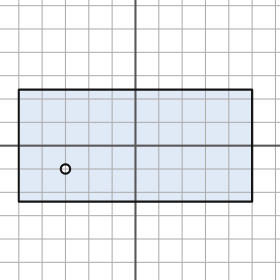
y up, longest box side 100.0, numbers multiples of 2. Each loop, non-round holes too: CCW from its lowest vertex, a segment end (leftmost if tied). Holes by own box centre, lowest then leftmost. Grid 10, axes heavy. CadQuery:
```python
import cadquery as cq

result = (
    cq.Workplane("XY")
    .moveTo(-50.0, -24.0)
    .lineTo(50.0, -24.0)
    .lineTo(50.0, 24.0)
    .lineTo(-50.0, 24.0)
    .close()
    .moveTo(-30.0, -10.0)
    .circle(2.0)
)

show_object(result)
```